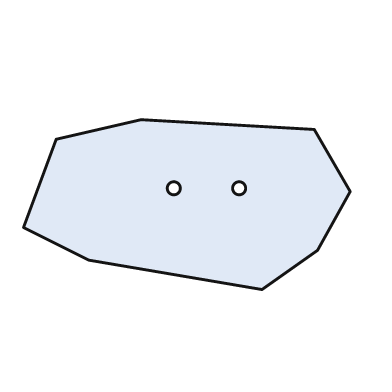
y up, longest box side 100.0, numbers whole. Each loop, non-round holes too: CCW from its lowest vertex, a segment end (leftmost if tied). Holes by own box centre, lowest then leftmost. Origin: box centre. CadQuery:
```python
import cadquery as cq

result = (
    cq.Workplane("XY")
    .moveTo(23.0, -26.0)
    .lineTo(40.0, -14.0)
    .lineTo(50.0, 4.0)
    .lineTo(39.0, 23.0)
    .lineTo(-14.0, 26.0)
    .lineTo(-40.0, 20.0)
    .lineTo(-50.0, -7.0)
    .lineTo(-30.0, -17.0)
    .close()
    .moveTo(-4.0, 5.0)
    .circle(2.0)
    .moveTo(16.0, 5.0)
    .circle(2.0)
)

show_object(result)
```